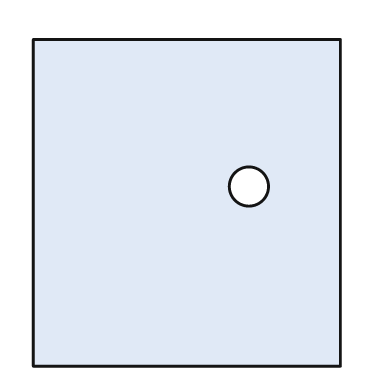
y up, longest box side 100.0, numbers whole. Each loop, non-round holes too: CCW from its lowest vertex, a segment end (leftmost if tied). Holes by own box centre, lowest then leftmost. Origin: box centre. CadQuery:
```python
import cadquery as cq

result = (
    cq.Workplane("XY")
    .moveTo(-47.0, -50.0)
    .lineTo(47.0, -50.0)
    .lineTo(47.0, 50.0)
    .lineTo(-47.0, 50.0)
    .close()
    .moveTo(19.0, 5.0)
    .circle(6.0)
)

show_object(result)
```